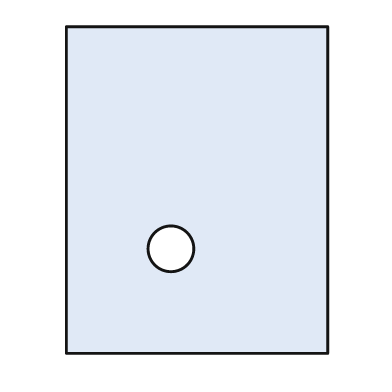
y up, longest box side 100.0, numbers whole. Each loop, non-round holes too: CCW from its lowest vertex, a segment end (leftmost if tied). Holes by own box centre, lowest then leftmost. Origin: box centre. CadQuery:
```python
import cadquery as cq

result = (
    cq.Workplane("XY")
    .moveTo(-40.0, -50.0)
    .lineTo(40.0, -50.0)
    .lineTo(40.0, 50.0)
    .lineTo(-40.0, 50.0)
    .close()
    .moveTo(-8.0, -18.0)
    .circle(7.0)
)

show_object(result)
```